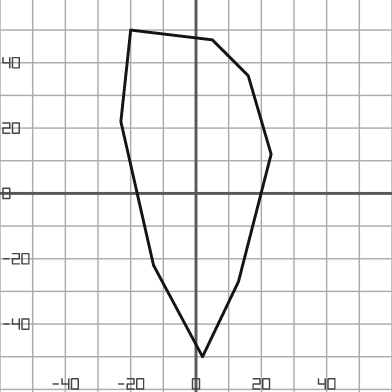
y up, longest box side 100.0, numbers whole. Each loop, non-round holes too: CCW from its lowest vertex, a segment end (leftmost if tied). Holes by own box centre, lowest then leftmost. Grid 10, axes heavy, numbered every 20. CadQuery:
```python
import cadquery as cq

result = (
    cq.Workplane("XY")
    .moveTo(2.0, -50.0)
    .lineTo(13.0, -27.0)
    .lineTo(23.0, 12.0)
    .lineTo(16.0, 36.0)
    .lineTo(5.0, 47.0)
    .lineTo(-20.0, 50.0)
    .lineTo(-23.0, 22.0)
    .lineTo(-13.0, -22.0)
    .close()
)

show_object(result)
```